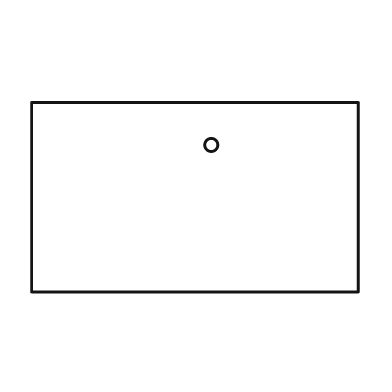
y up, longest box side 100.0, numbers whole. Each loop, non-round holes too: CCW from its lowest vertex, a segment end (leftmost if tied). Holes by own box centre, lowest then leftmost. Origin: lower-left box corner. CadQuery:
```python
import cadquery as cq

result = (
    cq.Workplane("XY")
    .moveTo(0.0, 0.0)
    .lineTo(100.0, 0.0)
    .lineTo(100.0, 58.0)
    .lineTo(0.0, 58.0)
    .close()
    .moveTo(55.0, 45.0)
    .circle(2.0)
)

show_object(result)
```